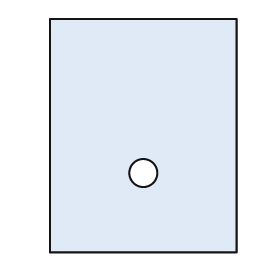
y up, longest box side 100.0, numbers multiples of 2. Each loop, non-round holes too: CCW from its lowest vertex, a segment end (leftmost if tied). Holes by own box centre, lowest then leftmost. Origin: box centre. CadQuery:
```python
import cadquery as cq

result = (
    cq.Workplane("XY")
    .moveTo(-40.0, -50.0)
    .lineTo(40.0, -50.0)
    .lineTo(40.0, 50.0)
    .lineTo(-40.0, 50.0)
    .close()
    .moveTo(0.0, -16.0)
    .circle(6.0)
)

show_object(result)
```